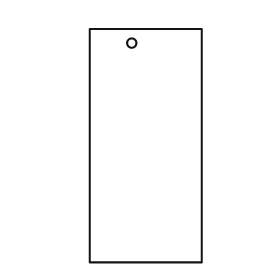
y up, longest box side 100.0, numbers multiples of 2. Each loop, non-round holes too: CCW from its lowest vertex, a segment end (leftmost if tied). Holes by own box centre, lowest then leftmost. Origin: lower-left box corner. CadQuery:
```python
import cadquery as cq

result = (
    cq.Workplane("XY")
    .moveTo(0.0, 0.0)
    .lineTo(48.0, 0.0)
    .lineTo(48.0, 100.0)
    .lineTo(0.0, 100.0)
    .close()
    .moveTo(18.0, 94.0)
    .circle(2.0)
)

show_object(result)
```